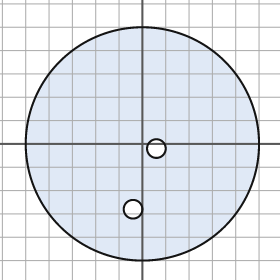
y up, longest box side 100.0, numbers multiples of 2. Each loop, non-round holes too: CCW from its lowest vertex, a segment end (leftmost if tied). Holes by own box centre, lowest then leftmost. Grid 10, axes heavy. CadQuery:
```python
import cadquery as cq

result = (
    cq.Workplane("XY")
    .moveTo(0.0, 0.0)
    .circle(50.0)
    .moveTo(-4.0, -28.0)
    .circle(4.0)
    .moveTo(6.0, -2.0)
    .circle(4.0)
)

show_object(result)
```